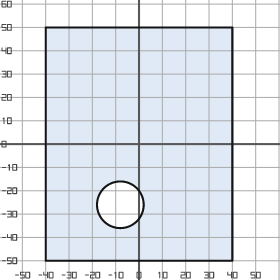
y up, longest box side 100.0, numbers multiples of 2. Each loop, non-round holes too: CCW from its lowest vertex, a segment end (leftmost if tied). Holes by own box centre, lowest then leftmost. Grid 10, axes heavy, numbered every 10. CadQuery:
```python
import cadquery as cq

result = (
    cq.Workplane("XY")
    .moveTo(-40.0, -50.0)
    .lineTo(40.0, -50.0)
    .lineTo(40.0, 50.0)
    .lineTo(-40.0, 50.0)
    .close()
    .moveTo(-8.0, -26.0)
    .circle(10.0)
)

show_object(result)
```